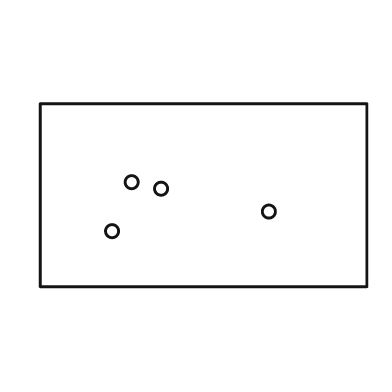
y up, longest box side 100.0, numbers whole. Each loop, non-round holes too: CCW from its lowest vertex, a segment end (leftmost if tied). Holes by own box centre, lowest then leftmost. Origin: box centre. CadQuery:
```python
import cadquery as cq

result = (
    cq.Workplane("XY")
    .moveTo(-50.0, -28.0)
    .lineTo(50.0, -28.0)
    .lineTo(50.0, 28.0)
    .lineTo(-50.0, 28.0)
    .close()
    .moveTo(-28.0, -11.0)
    .circle(2.0)
    .moveTo(20.0, -5.0)
    .circle(2.0)
    .moveTo(-13.0, 2.0)
    .circle(2.0)
    .moveTo(-22.0, 4.0)
    .circle(2.0)
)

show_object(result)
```